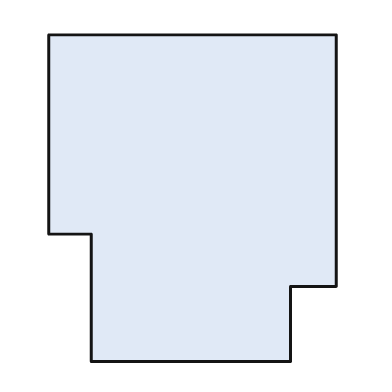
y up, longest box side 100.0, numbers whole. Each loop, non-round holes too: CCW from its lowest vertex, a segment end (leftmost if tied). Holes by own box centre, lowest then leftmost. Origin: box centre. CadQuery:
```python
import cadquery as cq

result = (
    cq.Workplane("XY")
    .moveTo(-31.0, -50.0)
    .lineTo(30.0, -50.0)
    .lineTo(30.0, -27.0)
    .lineTo(44.0, -27.0)
    .lineTo(44.0, 50.0)
    .lineTo(-44.0, 50.0)
    .lineTo(-44.0, -11.0)
    .lineTo(-31.0, -11.0)
    .close()
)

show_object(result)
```